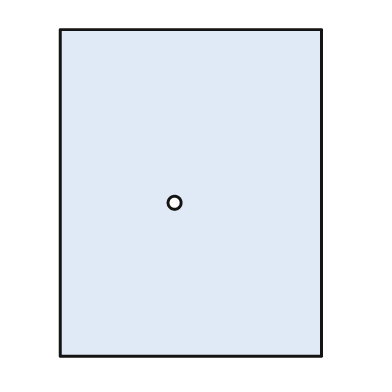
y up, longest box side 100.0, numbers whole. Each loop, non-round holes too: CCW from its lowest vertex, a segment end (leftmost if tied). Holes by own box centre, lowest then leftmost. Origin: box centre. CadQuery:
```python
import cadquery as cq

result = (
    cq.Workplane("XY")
    .moveTo(-40.0, -50.0)
    .lineTo(40.0, -50.0)
    .lineTo(40.0, 50.0)
    .lineTo(-40.0, 50.0)
    .close()
    .moveTo(-5.0, -3.0)
    .circle(2.0)
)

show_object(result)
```